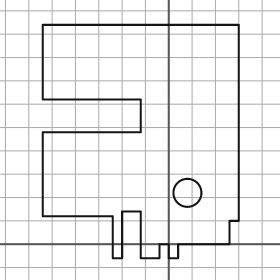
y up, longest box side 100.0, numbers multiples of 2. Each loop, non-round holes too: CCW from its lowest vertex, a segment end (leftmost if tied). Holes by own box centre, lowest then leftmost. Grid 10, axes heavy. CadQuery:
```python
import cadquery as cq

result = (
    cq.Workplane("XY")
    .moveTo(-24.0, -6.0)
    .lineTo(-20.0, -6.0)
    .lineTo(-20.0, 14.0)
    .lineTo(-12.0, 14.0)
    .lineTo(-12.0, -6.0)
    .lineTo(-4.0, -6.0)
    .lineTo(-4.0, 0.0)
    .lineTo(0.0, 0.0)
    .lineTo(0.0, -6.0)
    .lineTo(4.0, -6.0)
    .lineTo(4.0, 0.0)
    .lineTo(26.0, 0.0)
    .lineTo(26.0, 10.0)
    .lineTo(30.0, 10.0)
    .lineTo(30.0, 94.0)
    .lineTo(-54.0, 94.0)
    .lineTo(-54.0, 62.0)
    .lineTo(-12.0, 62.0)
    .lineTo(-12.0, 48.0)
    .lineTo(-54.0, 48.0)
    .lineTo(-54.0, 12.0)
    .lineTo(-24.0, 12.0)
    .close()
    .moveTo(8.0, 22.0)
    .circle(6.0)
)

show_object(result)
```